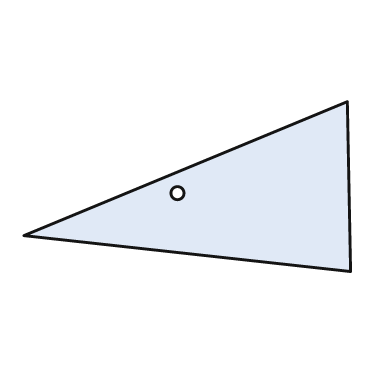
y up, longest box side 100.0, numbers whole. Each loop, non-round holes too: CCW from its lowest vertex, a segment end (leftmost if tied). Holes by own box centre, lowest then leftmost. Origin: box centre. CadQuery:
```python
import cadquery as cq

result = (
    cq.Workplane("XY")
    .moveTo(50.0, -26.0)
    .lineTo(49.0, 26.0)
    .lineTo(-50.0, -15.0)
    .close()
    .moveTo(-3.0, -2.0)
    .circle(2.0)
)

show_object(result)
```